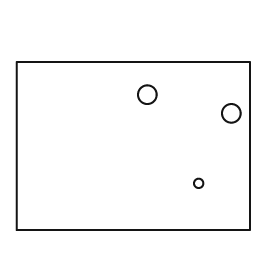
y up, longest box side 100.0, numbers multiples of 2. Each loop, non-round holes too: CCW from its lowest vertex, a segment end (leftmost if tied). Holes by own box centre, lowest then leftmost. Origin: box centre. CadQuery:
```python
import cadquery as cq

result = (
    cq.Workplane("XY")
    .moveTo(-50.0, -36.0)
    .lineTo(50.0, -36.0)
    .lineTo(50.0, 36.0)
    .lineTo(-50.0, 36.0)
    .close()
    .moveTo(28.0, -16.0)
    .circle(2.0)
    .moveTo(42.0, 14.0)
    .circle(4.0)
    .moveTo(6.0, 22.0)
    .circle(4.0)
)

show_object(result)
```